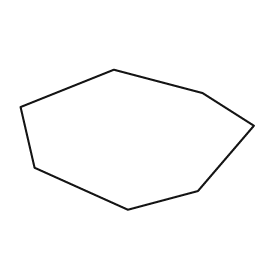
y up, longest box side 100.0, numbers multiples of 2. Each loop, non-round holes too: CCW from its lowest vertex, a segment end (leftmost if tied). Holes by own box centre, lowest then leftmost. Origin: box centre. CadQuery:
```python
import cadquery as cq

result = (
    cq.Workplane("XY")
    .moveTo(-4.0, -30.0)
    .lineTo(26.0, -22.0)
    .lineTo(50.0, 6.0)
    .lineTo(28.0, 20.0)
    .lineTo(-10.0, 30.0)
    .lineTo(-50.0, 14.0)
    .lineTo(-44.0, -12.0)
    .close()
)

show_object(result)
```